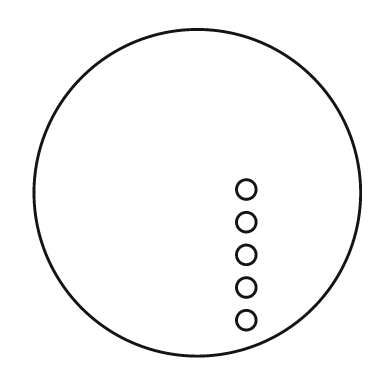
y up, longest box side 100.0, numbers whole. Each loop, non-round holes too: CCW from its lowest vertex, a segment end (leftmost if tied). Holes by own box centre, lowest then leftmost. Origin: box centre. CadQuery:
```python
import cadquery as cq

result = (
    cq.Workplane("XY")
    .moveTo(0.0, 0.0)
    .circle(50.0)
    .moveTo(15.0, -39.0)
    .circle(3.0)
    .moveTo(15.0, -29.0)
    .circle(3.0)
    .moveTo(15.0, -19.0)
    .circle(3.0)
    .moveTo(15.0, -9.0)
    .circle(3.0)
    .moveTo(15.0, 1.0)
    .circle(3.0)
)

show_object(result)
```